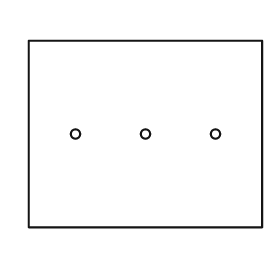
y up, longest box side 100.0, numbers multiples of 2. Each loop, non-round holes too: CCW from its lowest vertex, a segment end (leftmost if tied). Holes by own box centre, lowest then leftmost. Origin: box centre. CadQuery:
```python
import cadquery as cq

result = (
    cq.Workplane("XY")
    .moveTo(-50.0, -40.0)
    .lineTo(50.0, -40.0)
    .lineTo(50.0, 40.0)
    .lineTo(-50.0, 40.0)
    .close()
    .moveTo(-30.0, 0.0)
    .circle(2.0)
    .moveTo(0.0, 0.0)
    .circle(2.0)
    .moveTo(30.0, 0.0)
    .circle(2.0)
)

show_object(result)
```